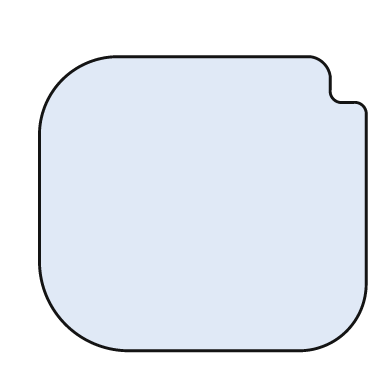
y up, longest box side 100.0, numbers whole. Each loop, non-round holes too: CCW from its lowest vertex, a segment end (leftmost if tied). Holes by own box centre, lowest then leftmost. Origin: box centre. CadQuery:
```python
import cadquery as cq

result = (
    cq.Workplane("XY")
    .moveTo(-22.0, -45.0)
    .lineTo(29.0, -45.0)
    .threePointArc((44.0, -39.0), (50.0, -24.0))
    .lineTo(50.0, 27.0)
    .threePointArc((49.0, 30.0), (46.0, 31.0))
    .lineTo(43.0, 31.0)
    .threePointArc((40.0, 32.0), (39.0, 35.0))
    .lineTo(39.0, 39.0)
    .threePointArc((37.0, 43.0), (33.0, 45.0))
    .lineTo(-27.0, 45.0)
    .threePointArc((-43.0, 38.0), (-50.0, 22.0))
    .lineTo(-50.0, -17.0)
    .threePointArc((-42.0, -37.0), (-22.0, -45.0))
    .close()
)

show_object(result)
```